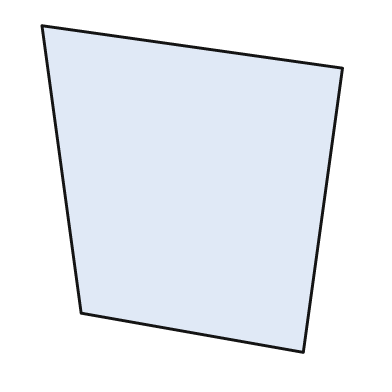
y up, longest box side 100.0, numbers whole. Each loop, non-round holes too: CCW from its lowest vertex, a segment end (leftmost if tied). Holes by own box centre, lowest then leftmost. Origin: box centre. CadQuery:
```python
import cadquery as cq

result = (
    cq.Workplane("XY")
    .moveTo(34.0, -50.0)
    .lineTo(46.0, 37.0)
    .lineTo(-46.0, 50.0)
    .lineTo(-34.0, -38.0)
    .close()
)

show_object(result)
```